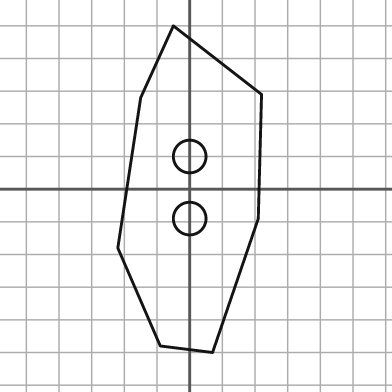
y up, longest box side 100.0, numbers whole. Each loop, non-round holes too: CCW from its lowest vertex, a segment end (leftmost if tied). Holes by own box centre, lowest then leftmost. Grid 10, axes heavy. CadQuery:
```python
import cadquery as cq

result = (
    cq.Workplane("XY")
    .moveTo(7.0, -50.0)
    .lineTo(21.0, -9.0)
    .lineTo(22.0, 29.0)
    .lineTo(-5.0, 50.0)
    .lineTo(-15.0, 28.0)
    .lineTo(-22.0, -18.0)
    .lineTo(-9.0, -48.0)
    .close()
    .moveTo(0.0, -9.0)
    .circle(5.0)
    .moveTo(0.0, 10.0)
    .circle(5.0)
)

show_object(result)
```